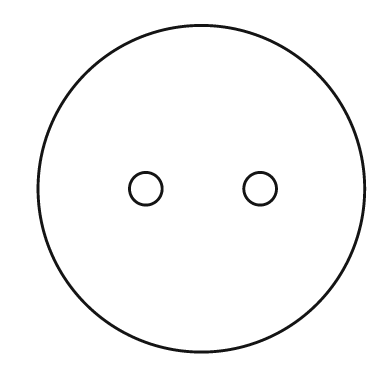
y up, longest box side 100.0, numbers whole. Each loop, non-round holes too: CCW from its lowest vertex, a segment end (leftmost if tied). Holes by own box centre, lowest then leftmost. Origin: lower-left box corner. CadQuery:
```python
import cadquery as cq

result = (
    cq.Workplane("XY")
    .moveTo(50.0, 50.0)
    .circle(50.0)
    .moveTo(33.0, 50.0)
    .circle(5.0)
    .moveTo(68.0, 50.0)
    .circle(5.0)
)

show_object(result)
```